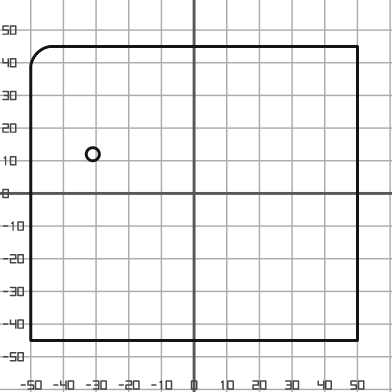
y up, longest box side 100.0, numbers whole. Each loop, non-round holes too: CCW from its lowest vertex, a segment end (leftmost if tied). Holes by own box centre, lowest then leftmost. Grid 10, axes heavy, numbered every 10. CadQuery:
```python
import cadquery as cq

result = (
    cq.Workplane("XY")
    .moveTo(-50.0, -45.0)
    .lineTo(50.0, -45.0)
    .lineTo(50.0, 45.0)
    .lineTo(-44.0, 45.0)
    .threePointArc((-48.0, 43.0), (-50.0, 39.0))
    .close()
    .moveTo(-31.0, 12.0)
    .circle(2.0)
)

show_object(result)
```